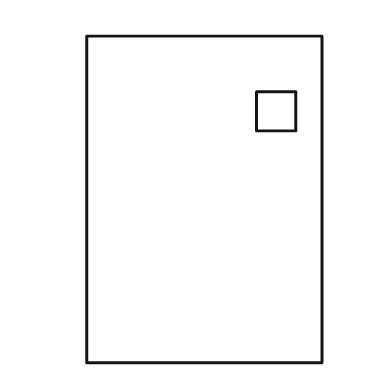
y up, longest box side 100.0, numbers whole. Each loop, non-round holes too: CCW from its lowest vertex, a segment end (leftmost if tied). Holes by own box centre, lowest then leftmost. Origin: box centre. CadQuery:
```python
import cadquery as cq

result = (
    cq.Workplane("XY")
    .moveTo(-36.0, -50.0)
    .lineTo(36.0, -50.0)
    .lineTo(36.0, 50.0)
    .lineTo(-36.0, 50.0)
    .close()
    .moveTo(16.0, 21.0)
    .lineTo(28.0, 21.0)
    .lineTo(28.0, 33.0)
    .lineTo(16.0, 33.0)
    .close()
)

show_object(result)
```